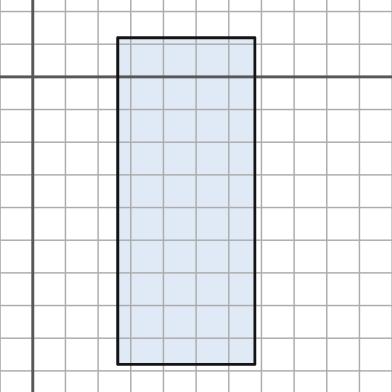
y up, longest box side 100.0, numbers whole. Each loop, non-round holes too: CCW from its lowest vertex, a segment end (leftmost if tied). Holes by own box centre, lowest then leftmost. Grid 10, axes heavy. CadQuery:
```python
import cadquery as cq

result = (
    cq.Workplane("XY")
    .moveTo(26.0, -88.0)
    .lineTo(68.0, -88.0)
    .lineTo(68.0, 12.0)
    .lineTo(26.0, 12.0)
    .close()
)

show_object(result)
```